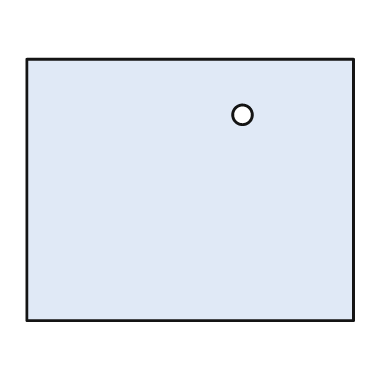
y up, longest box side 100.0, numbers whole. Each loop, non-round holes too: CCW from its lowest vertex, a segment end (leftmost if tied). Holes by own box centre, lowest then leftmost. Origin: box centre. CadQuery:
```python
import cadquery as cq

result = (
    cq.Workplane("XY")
    .moveTo(-50.0, -40.0)
    .lineTo(50.0, -40.0)
    .lineTo(50.0, 40.0)
    .lineTo(-50.0, 40.0)
    .close()
    .moveTo(16.0, 23.0)
    .circle(3.0)
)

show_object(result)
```